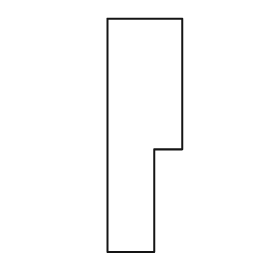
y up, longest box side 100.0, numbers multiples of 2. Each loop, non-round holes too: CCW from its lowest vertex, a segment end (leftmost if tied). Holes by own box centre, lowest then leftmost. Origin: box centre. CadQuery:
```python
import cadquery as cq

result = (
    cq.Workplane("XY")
    .moveTo(-16.0, -50.0)
    .lineTo(4.0, -50.0)
    .lineTo(4.0, -6.0)
    .lineTo(16.0, -6.0)
    .lineTo(16.0, 50.0)
    .lineTo(-16.0, 50.0)
    .close()
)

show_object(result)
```